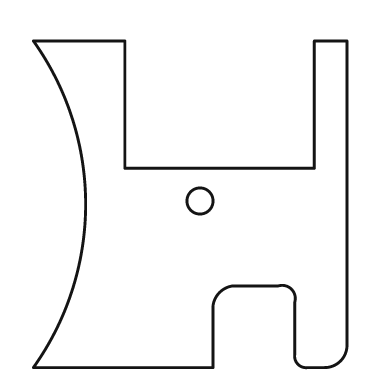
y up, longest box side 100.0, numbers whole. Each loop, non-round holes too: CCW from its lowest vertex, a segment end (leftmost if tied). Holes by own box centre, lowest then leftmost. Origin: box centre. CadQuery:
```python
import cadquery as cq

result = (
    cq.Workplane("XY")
    .moveTo(-48.0, -50.0)
    .lineTo(7.0, -50.0)
    .lineTo(7.0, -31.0)
    .threePointArc((9.0, -27.0), (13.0, -25.0))
    .lineTo(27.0, -25.0)
    .threePointArc((31.0, -26.0), (32.0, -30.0))
    .lineTo(32.0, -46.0)
    .threePointArc((33.0, -49.0), (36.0, -50.0))
    .lineTo(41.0, -50.0)
    .threePointArc((46.0, -48.0), (48.0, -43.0))
    .lineTo(48.0, 50.0)
    .lineTo(38.0, 50.0)
    .lineTo(38.0, 11.0)
    .lineTo(-20.0, 11.0)
    .lineTo(-20.0, 50.0)
    .lineTo(-48.0, 50.0)
    .threePointArc((-32.0, 0.0), (-48.0, -50.0))
    .close()
    .moveTo(3.0, 1.0)
    .circle(4.0)
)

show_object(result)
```